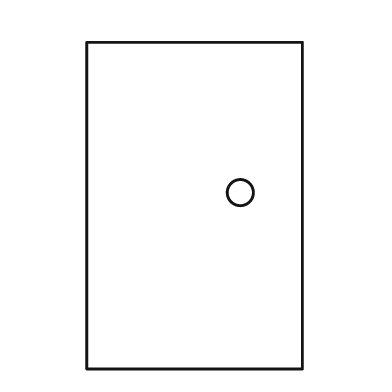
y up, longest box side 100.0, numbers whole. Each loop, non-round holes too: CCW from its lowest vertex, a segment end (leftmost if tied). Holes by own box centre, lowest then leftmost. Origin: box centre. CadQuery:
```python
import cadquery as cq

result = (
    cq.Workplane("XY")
    .moveTo(-33.0, -50.0)
    .lineTo(33.0, -50.0)
    .lineTo(33.0, 50.0)
    .lineTo(-33.0, 50.0)
    .close()
    .moveTo(14.0, 4.0)
    .circle(4.0)
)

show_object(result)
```